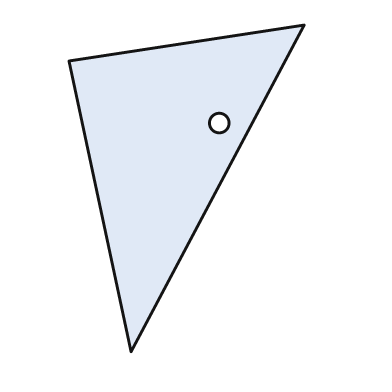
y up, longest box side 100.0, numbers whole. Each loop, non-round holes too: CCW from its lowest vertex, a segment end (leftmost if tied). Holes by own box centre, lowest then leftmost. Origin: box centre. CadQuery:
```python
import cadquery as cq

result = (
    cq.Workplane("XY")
    .moveTo(-17.0, -50.0)
    .lineTo(36.0, 50.0)
    .lineTo(-36.0, 39.0)
    .close()
    .moveTo(10.0, 20.0)
    .circle(3.0)
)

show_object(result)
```